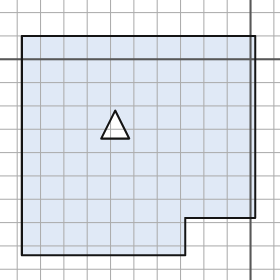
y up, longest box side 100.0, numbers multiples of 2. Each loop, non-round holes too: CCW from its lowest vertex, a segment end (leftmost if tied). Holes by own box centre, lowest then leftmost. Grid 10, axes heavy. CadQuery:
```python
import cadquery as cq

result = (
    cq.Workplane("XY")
    .moveTo(-98.0, -84.0)
    .lineTo(-28.0, -84.0)
    .lineTo(-28.0, -68.0)
    .lineTo(2.0, -68.0)
    .lineTo(2.0, 10.0)
    .lineTo(-98.0, 10.0)
    .close()
    .moveTo(-64.0, -34.0)
    .lineTo(-52.0, -34.0)
    .lineTo(-58.0, -22.0)
    .close()
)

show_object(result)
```